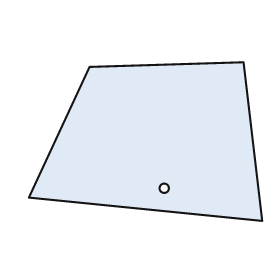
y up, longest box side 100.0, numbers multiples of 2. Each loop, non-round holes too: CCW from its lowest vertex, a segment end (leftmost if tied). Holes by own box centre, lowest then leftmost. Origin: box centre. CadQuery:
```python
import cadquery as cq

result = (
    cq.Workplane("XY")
    .moveTo(50.0, -34.0)
    .lineTo(42.0, 34.0)
    .lineTo(-24.0, 32.0)
    .lineTo(-50.0, -24.0)
    .close()
    .moveTo(8.0, -20.0)
    .circle(2.0)
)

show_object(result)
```